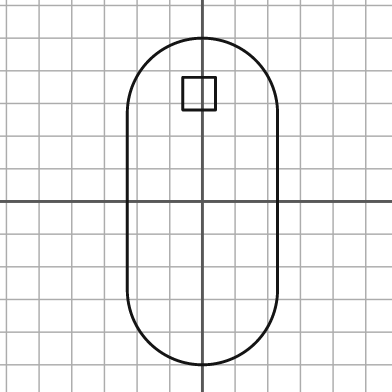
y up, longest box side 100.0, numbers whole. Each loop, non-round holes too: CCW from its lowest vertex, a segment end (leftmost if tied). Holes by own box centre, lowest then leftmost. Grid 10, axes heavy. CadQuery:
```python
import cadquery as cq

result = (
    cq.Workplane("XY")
    .moveTo(-23.0, -27.0)
    .threePointArc((0.0, -50.0), (23.0, -27.0))
    .lineTo(23.0, 27.0)
    .threePointArc((0.0, 50.0), (-23.0, 27.0))
    .close()
    .moveTo(-6.0, 28.0)
    .lineTo(4.0, 28.0)
    .lineTo(4.0, 38.0)
    .lineTo(-6.0, 38.0)
    .close()
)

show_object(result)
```